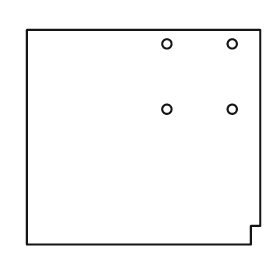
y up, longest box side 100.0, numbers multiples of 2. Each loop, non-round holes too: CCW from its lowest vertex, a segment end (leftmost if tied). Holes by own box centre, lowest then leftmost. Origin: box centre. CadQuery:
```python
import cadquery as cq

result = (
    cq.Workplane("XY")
    .moveTo(-50.0, -46.0)
    .lineTo(46.0, -46.0)
    .lineTo(46.0, -38.0)
    .lineTo(50.0, -38.0)
    .lineTo(50.0, 46.0)
    .lineTo(-50.0, 46.0)
    .close()
    .moveTo(10.0, 12.0)
    .circle(2.0)
    .moveTo(38.0, 12.0)
    .circle(2.0)
    .moveTo(10.0, 40.0)
    .circle(2.0)
    .moveTo(38.0, 40.0)
    .circle(2.0)
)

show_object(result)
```